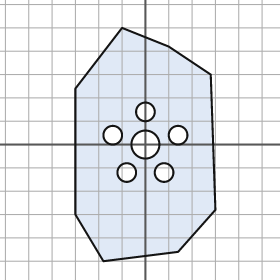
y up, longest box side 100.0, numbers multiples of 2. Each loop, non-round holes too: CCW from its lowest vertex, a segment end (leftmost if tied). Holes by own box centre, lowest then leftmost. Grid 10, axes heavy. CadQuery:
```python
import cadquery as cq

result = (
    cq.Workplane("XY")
    .moveTo(-18.0, -50.0)
    .lineTo(14.0, -46.0)
    .lineTo(30.0, -28.0)
    .lineTo(28.0, 30.0)
    .lineTo(10.0, 42.0)
    .lineTo(-10.0, 50.0)
    .lineTo(-30.0, 24.0)
    .lineTo(-30.0, -30.0)
    .close()
    .moveTo(-8.0, -12.0)
    .circle(4.0)
    .moveTo(8.0, -12.0)
    .circle(4.0)
    .moveTo(0.0, 0.0)
    .circle(6.0)
    .moveTo(-14.0, 4.0)
    .circle(4.0)
    .moveTo(14.0, 4.0)
    .circle(4.0)
    .moveTo(0.0, 14.0)
    .circle(4.0)
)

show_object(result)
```